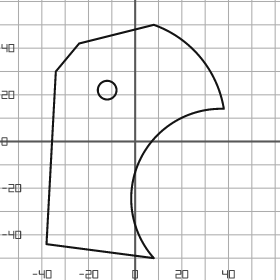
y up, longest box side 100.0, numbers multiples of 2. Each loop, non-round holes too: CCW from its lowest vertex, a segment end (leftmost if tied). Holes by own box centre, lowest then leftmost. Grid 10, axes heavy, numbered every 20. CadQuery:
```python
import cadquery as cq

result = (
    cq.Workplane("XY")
    .moveTo(8.0, -50.0)
    .threePointArc((2.0, -8.0), (38.0, 14.0))
    .threePointArc((28.0, 36.0), (8.0, 50.0))
    .lineTo(-24.0, 42.0)
    .lineTo(-34.0, 30.0)
    .lineTo(-38.0, -44.0)
    .close()
    .moveTo(-12.0, 22.0)
    .circle(4.0)
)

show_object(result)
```